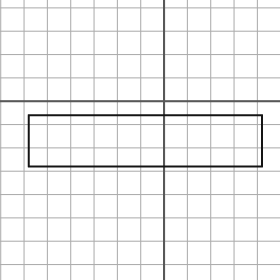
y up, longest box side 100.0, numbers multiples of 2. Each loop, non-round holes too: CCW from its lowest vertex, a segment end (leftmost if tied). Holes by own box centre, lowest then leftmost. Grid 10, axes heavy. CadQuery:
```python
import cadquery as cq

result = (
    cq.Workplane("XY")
    .moveTo(-58.0, -28.0)
    .lineTo(42.0, -28.0)
    .lineTo(42.0, -6.0)
    .lineTo(-58.0, -6.0)
    .close()
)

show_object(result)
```